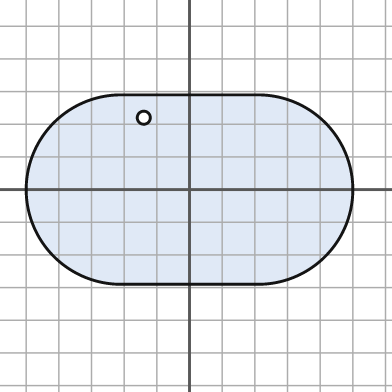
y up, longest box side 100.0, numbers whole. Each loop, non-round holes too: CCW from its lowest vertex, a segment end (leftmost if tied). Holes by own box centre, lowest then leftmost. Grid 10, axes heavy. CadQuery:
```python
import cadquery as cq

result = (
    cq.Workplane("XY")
    .moveTo(-21.0, -29.0)
    .lineTo(21.0, -29.0)
    .threePointArc((50.0, 0.0), (21.0, 29.0))
    .lineTo(-21.0, 29.0)
    .threePointArc((-50.0, 0.0), (-21.0, -29.0))
    .close()
    .moveTo(-14.0, 22.0)
    .circle(2.0)
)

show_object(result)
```